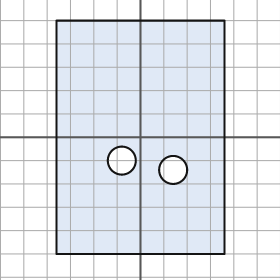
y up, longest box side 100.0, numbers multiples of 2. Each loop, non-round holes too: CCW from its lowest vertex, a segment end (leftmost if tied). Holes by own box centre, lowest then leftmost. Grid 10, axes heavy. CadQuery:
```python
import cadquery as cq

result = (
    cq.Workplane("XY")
    .moveTo(-36.0, -50.0)
    .lineTo(36.0, -50.0)
    .lineTo(36.0, 50.0)
    .lineTo(-36.0, 50.0)
    .close()
    .moveTo(14.0, -14.0)
    .circle(6.0)
    .moveTo(-8.0, -10.0)
    .circle(6.0)
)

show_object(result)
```